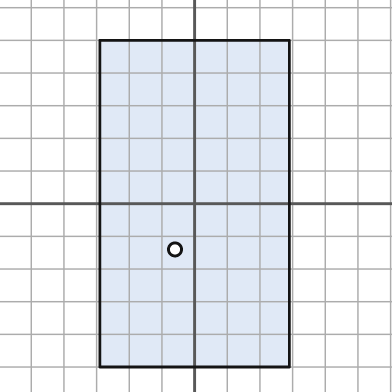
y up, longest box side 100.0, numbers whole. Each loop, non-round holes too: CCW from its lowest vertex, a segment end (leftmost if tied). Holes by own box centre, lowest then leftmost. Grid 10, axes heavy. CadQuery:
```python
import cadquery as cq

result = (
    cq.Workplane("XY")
    .moveTo(-29.0, -50.0)
    .lineTo(29.0, -50.0)
    .lineTo(29.0, 50.0)
    .lineTo(-29.0, 50.0)
    .close()
    .moveTo(-6.0, -14.0)
    .circle(2.0)
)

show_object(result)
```